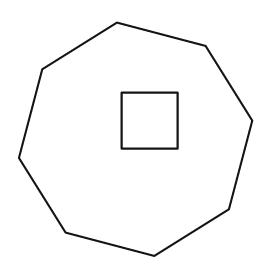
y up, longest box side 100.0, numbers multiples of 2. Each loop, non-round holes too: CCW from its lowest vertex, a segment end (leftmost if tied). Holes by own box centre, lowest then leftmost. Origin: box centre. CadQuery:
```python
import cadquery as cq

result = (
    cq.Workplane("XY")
    .moveTo(8.0, -50.0)
    .lineTo(40.0, -30.0)
    .lineTo(50.0, 8.0)
    .lineTo(30.0, 40.0)
    .lineTo(-8.0, 50.0)
    .lineTo(-40.0, 30.0)
    .lineTo(-50.0, -8.0)
    .lineTo(-30.0, -40.0)
    .close()
    .moveTo(-6.0, -4.0)
    .lineTo(18.0, -4.0)
    .lineTo(18.0, 20.0)
    .lineTo(-6.0, 20.0)
    .close()
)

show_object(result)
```